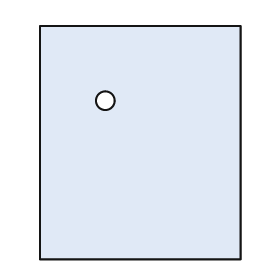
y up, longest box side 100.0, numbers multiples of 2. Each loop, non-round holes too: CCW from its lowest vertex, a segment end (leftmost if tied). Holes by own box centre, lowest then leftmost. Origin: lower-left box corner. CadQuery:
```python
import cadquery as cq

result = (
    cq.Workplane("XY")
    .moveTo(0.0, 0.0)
    .lineTo(86.0, 0.0)
    .lineTo(86.0, 100.0)
    .lineTo(0.0, 100.0)
    .close()
    .moveTo(28.0, 68.0)
    .circle(4.0)
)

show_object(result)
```